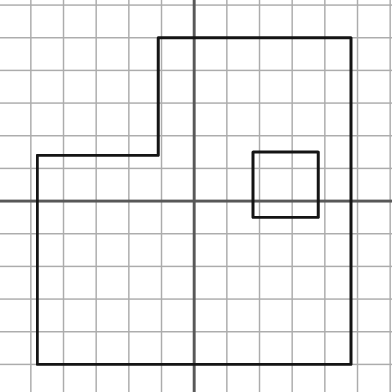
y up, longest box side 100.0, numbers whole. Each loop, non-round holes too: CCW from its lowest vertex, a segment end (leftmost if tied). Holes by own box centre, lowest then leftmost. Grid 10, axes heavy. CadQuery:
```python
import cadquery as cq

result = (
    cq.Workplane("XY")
    .moveTo(-48.0, -50.0)
    .lineTo(48.0, -50.0)
    .lineTo(48.0, 50.0)
    .lineTo(-11.0, 50.0)
    .lineTo(-11.0, 14.0)
    .lineTo(-48.0, 14.0)
    .close()
    .moveTo(18.0, -5.0)
    .lineTo(38.0, -5.0)
    .lineTo(38.0, 15.0)
    .lineTo(18.0, 15.0)
    .close()
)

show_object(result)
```